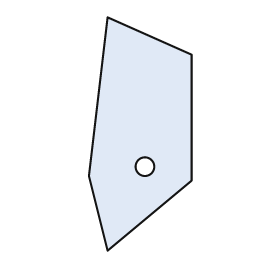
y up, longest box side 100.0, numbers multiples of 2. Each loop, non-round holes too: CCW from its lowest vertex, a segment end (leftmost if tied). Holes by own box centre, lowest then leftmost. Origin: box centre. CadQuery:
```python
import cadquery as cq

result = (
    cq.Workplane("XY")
    .moveTo(-14.0, -50.0)
    .lineTo(22.0, -20.0)
    .lineTo(22.0, 34.0)
    .lineTo(-14.0, 50.0)
    .lineTo(-22.0, -18.0)
    .close()
    .moveTo(2.0, -14.0)
    .circle(4.0)
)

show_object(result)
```